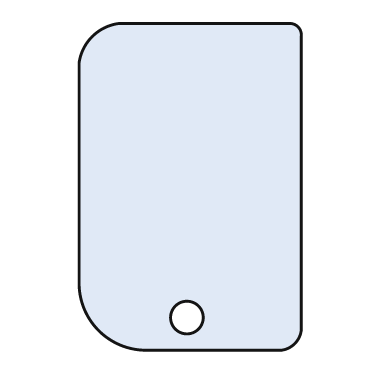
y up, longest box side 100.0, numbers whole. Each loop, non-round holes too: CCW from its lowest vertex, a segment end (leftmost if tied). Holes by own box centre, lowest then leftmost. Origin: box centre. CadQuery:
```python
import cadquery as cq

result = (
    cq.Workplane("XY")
    .moveTo(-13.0, -50.0)
    .lineTo(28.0, -50.0)
    .threePointArc((32.0, -48.0), (34.0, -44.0))
    .lineTo(34.0, 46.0)
    .threePointArc((33.0, 49.0), (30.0, 50.0))
    .lineTo(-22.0, 50.0)
    .threePointArc((-30.0, 46.0), (-34.0, 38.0))
    .lineTo(-34.0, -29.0)
    .threePointArc((-28.0, -44.0), (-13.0, -50.0))
    .close()
    .moveTo(-1.0, -40.0)
    .circle(5.0)
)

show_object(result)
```